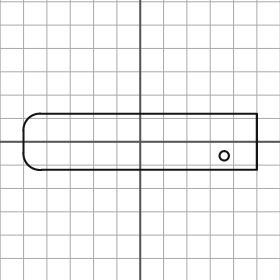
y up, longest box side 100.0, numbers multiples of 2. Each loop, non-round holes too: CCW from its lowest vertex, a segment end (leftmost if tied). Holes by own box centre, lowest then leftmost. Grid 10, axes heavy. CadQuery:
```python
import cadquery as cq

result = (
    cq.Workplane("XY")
    .moveTo(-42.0, -12.0)
    .lineTo(50.0, -12.0)
    .lineTo(50.0, 12.0)
    .lineTo(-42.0, 12.0)
    .threePointArc((-48.0, 10.0), (-50.0, 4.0))
    .lineTo(-50.0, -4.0)
    .threePointArc((-48.0, -10.0), (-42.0, -12.0))
    .close()
    .moveTo(36.0, -6.0)
    .circle(2.0)
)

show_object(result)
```